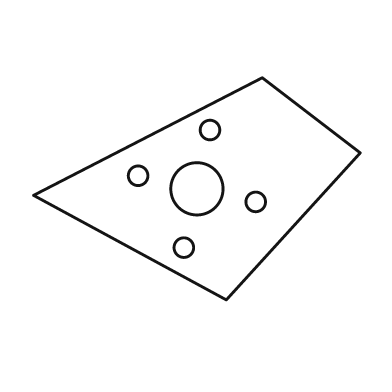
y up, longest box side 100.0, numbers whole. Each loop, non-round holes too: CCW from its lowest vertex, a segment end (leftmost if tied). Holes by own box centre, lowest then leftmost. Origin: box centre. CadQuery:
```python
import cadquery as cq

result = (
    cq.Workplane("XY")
    .moveTo(9.0, -34.0)
    .lineTo(50.0, 11.0)
    .lineTo(20.0, 34.0)
    .lineTo(-50.0, -2.0)
    .close()
    .moveTo(-4.0, -18.0)
    .circle(3.0)
    .moveTo(18.0, -4.0)
    .circle(3.0)
    .moveTo(0.0, 0.0)
    .circle(8.0)
    .moveTo(-18.0, 4.0)
    .circle(3.0)
    .moveTo(4.0, 18.0)
    .circle(3.0)
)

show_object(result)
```